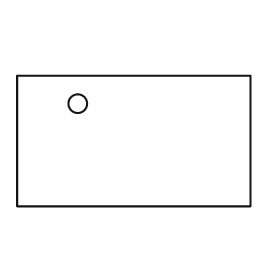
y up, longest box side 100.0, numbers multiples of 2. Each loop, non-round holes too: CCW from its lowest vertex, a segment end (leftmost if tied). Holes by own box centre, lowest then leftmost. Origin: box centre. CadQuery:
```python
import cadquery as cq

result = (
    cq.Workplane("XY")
    .moveTo(-50.0, -28.0)
    .lineTo(50.0, -28.0)
    .lineTo(50.0, 28.0)
    .lineTo(-50.0, 28.0)
    .close()
    .moveTo(-24.0, 16.0)
    .circle(4.0)
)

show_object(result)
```